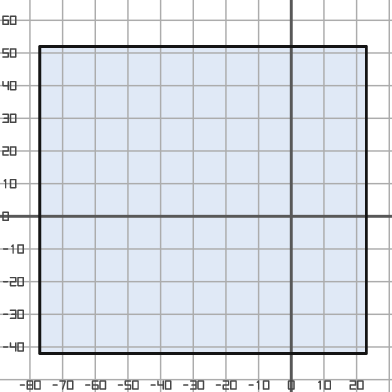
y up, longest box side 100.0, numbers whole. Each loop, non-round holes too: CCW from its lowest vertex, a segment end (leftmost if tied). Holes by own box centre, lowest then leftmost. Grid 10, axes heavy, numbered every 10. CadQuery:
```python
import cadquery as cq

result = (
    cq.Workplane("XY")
    .moveTo(-77.0, -42.0)
    .lineTo(23.0, -42.0)
    .lineTo(23.0, 52.0)
    .lineTo(-77.0, 52.0)
    .close()
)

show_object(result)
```